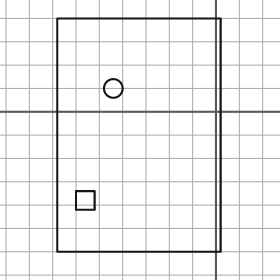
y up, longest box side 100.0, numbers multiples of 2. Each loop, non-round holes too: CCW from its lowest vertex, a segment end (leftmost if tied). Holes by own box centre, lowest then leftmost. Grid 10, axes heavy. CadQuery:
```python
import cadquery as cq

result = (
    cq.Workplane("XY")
    .moveTo(-68.0, -60.0)
    .lineTo(2.0, -60.0)
    .lineTo(2.0, 40.0)
    .lineTo(-68.0, 40.0)
    .close()
    .moveTo(-60.0, -42.0)
    .lineTo(-52.0, -42.0)
    .lineTo(-52.0, -34.0)
    .lineTo(-60.0, -34.0)
    .close()
    .moveTo(-44.0, 10.0)
    .circle(4.0)
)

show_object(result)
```